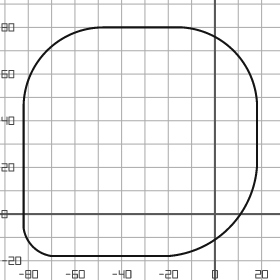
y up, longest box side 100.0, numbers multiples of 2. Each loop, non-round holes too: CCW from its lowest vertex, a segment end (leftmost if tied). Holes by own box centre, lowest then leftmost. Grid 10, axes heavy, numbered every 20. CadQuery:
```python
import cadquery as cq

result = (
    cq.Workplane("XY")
    .moveTo(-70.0, -18.0)
    .lineTo(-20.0, -18.0)
    .threePointArc((6.0, -6.0), (18.0, 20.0))
    .lineTo(18.0, 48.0)
    .threePointArc((8.0, 70.0), (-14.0, 80.0))
    .lineTo(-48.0, 80.0)
    .threePointArc((-72.0, 70.0), (-82.0, 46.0))
    .lineTo(-82.0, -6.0)
    .threePointArc((-78.0, -14.0), (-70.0, -18.0))
    .close()
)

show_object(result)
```